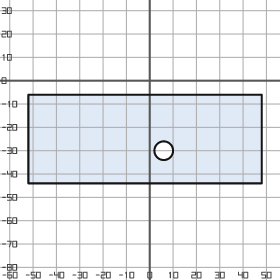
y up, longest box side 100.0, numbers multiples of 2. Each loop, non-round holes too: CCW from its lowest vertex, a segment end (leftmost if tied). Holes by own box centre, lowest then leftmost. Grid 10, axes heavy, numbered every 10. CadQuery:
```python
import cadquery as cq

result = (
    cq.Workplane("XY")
    .moveTo(-52.0, -44.0)
    .lineTo(48.0, -44.0)
    .lineTo(48.0, -6.0)
    .lineTo(-52.0, -6.0)
    .close()
    .moveTo(6.0, -30.0)
    .circle(4.0)
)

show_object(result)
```